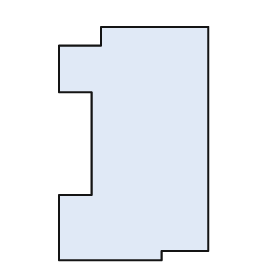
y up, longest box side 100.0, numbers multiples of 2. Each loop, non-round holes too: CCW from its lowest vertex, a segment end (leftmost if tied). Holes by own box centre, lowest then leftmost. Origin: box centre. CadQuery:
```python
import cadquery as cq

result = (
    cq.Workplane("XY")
    .moveTo(-32.0, -50.0)
    .lineTo(12.0, -50.0)
    .lineTo(12.0, -46.0)
    .lineTo(32.0, -46.0)
    .lineTo(32.0, 50.0)
    .lineTo(-14.0, 50.0)
    .lineTo(-14.0, 42.0)
    .lineTo(-32.0, 42.0)
    .lineTo(-32.0, 22.0)
    .lineTo(-18.0, 22.0)
    .lineTo(-18.0, -22.0)
    .lineTo(-32.0, -22.0)
    .close()
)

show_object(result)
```